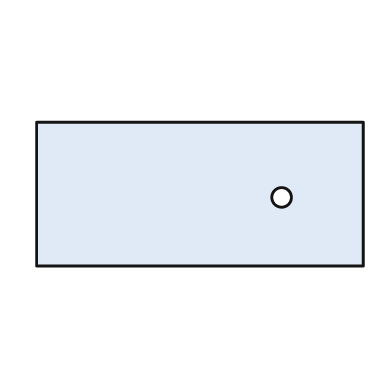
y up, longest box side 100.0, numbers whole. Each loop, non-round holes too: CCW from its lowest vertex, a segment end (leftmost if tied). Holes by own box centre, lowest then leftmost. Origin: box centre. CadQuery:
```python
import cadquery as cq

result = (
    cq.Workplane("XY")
    .moveTo(-50.0, -22.0)
    .lineTo(50.0, -22.0)
    .lineTo(50.0, 22.0)
    .lineTo(-50.0, 22.0)
    .close()
    .moveTo(25.0, -1.0)
    .circle(3.0)
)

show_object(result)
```